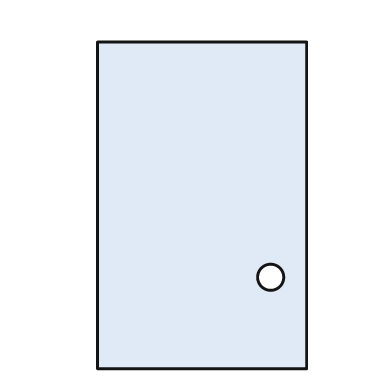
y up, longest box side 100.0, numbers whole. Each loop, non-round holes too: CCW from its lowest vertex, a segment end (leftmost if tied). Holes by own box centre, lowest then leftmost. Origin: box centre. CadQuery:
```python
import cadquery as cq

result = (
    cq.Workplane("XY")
    .moveTo(-32.0, -50.0)
    .lineTo(32.0, -50.0)
    .lineTo(32.0, 50.0)
    .lineTo(-32.0, 50.0)
    .close()
    .moveTo(21.0, -22.0)
    .circle(4.0)
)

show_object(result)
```